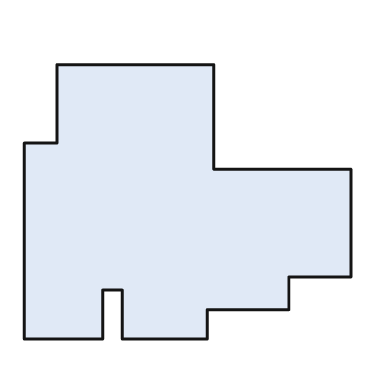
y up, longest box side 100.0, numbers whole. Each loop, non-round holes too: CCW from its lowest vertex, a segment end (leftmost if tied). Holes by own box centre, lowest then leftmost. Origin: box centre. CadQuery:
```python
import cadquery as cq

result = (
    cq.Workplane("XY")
    .moveTo(-50.0, -42.0)
    .lineTo(-26.0, -42.0)
    .lineTo(-26.0, -27.0)
    .lineTo(-20.0, -27.0)
    .lineTo(-20.0, -42.0)
    .lineTo(6.0, -42.0)
    .lineTo(6.0, -33.0)
    .lineTo(31.0, -33.0)
    .lineTo(31.0, -23.0)
    .lineTo(50.0, -23.0)
    .lineTo(50.0, 10.0)
    .lineTo(8.0, 10.0)
    .lineTo(8.0, 42.0)
    .lineTo(-40.0, 42.0)
    .lineTo(-40.0, 18.0)
    .lineTo(-50.0, 18.0)
    .close()
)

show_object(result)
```